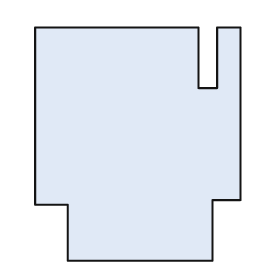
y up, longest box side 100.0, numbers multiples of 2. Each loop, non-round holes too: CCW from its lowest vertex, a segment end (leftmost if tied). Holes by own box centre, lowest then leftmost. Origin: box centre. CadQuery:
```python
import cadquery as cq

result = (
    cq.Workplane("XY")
    .moveTo(-30.0, -50.0)
    .lineTo(32.0, -50.0)
    .lineTo(32.0, -24.0)
    .lineTo(44.0, -24.0)
    .lineTo(44.0, 50.0)
    .lineTo(34.0, 50.0)
    .lineTo(34.0, 24.0)
    .lineTo(26.0, 24.0)
    .lineTo(26.0, 50.0)
    .lineTo(-44.0, 50.0)
    .lineTo(-44.0, -26.0)
    .lineTo(-30.0, -26.0)
    .close()
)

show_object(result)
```